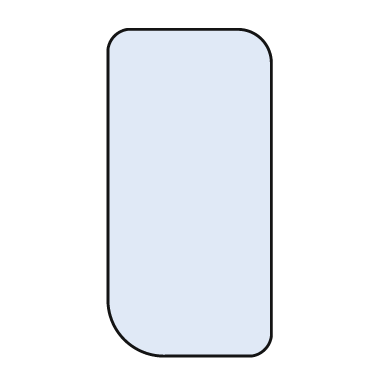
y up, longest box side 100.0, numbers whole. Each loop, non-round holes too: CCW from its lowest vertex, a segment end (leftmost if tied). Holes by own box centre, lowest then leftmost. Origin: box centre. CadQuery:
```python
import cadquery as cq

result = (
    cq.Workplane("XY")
    .moveTo(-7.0, -50.0)
    .lineTo(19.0, -50.0)
    .threePointArc((23.0, -48.0), (25.0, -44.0))
    .lineTo(25.0, 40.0)
    .threePointArc((22.0, 47.0), (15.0, 50.0))
    .lineTo(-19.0, 50.0)
    .threePointArc((-23.0, 48.0), (-25.0, 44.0))
    .lineTo(-25.0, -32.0)
    .threePointArc((-20.0, -45.0), (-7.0, -50.0))
    .close()
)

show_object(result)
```